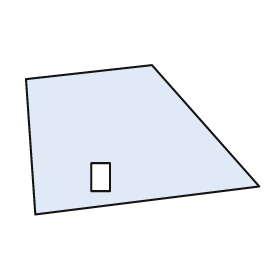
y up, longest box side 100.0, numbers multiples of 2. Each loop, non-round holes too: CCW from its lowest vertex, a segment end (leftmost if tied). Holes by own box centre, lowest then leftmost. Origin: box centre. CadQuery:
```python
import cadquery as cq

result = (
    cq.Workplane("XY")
    .moveTo(-46.0, -32.0)
    .lineTo(50.0, -20.0)
    .lineTo(4.0, 32.0)
    .lineTo(-50.0, 26.0)
    .close()
    .moveTo(-22.0, -22.0)
    .lineTo(-14.0, -22.0)
    .lineTo(-14.0, -10.0)
    .lineTo(-22.0, -10.0)
    .close()
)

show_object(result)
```